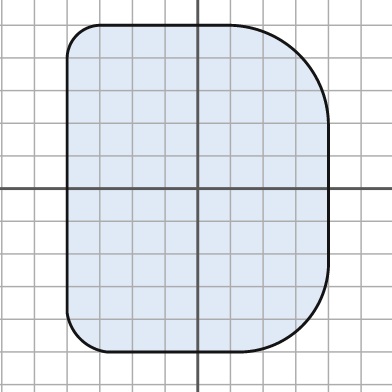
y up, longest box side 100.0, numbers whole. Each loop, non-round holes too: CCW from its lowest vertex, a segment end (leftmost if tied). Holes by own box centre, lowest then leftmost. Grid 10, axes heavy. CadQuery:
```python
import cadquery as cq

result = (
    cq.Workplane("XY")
    .moveTo(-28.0, -50.0)
    .lineTo(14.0, -50.0)
    .threePointArc((32.0, -42.0), (40.0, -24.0))
    .lineTo(40.0, 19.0)
    .threePointArc((31.0, 41.0), (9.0, 50.0))
    .lineTo(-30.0, 50.0)
    .threePointArc((-37.0, 47.0), (-40.0, 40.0))
    .lineTo(-40.0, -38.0)
    .threePointArc((-36.0, -46.0), (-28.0, -50.0))
    .close()
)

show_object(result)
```